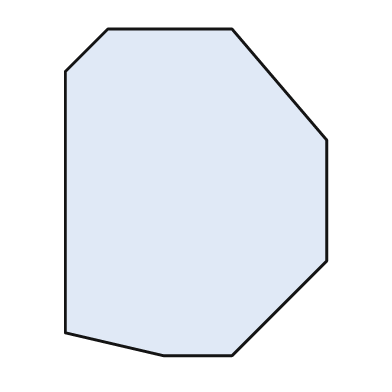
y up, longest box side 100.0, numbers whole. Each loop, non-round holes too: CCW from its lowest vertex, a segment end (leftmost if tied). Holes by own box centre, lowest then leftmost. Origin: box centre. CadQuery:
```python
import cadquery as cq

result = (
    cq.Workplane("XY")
    .moveTo(-10.0, -50.0)
    .lineTo(11.0, -50.0)
    .lineTo(40.0, -21.0)
    .lineTo(40.0, 16.0)
    .lineTo(11.0, 50.0)
    .lineTo(-27.0, 50.0)
    .lineTo(-40.0, 37.0)
    .lineTo(-40.0, -43.0)
    .close()
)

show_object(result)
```